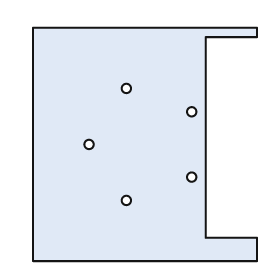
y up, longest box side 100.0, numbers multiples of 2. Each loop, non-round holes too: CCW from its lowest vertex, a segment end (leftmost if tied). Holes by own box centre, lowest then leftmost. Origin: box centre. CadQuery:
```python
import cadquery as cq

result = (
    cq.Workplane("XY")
    .moveTo(-48.0, -50.0)
    .lineTo(48.0, -50.0)
    .lineTo(48.0, -40.0)
    .lineTo(26.0, -40.0)
    .lineTo(26.0, 46.0)
    .lineTo(48.0, 46.0)
    .lineTo(48.0, 50.0)
    .lineTo(-48.0, 50.0)
    .close()
    .moveTo(-8.0, -24.0)
    .circle(2.0)
    .moveTo(20.0, -14.0)
    .circle(2.0)
    .moveTo(-24.0, 0.0)
    .circle(2.0)
    .moveTo(20.0, 14.0)
    .circle(2.0)
    .moveTo(-8.0, 24.0)
    .circle(2.0)
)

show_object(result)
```